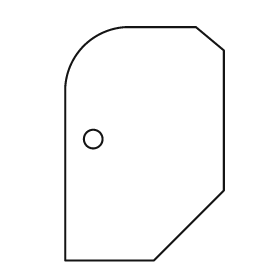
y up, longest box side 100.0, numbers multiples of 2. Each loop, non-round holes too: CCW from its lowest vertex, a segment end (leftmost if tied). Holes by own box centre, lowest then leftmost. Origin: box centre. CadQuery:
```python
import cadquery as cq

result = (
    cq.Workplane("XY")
    .moveTo(-34.0, -50.0)
    .lineTo(4.0, -50.0)
    .lineTo(34.0, -20.0)
    .lineTo(34.0, 40.0)
    .lineTo(22.0, 50.0)
    .lineTo(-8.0, 50.0)
    .threePointArc((-26.0, 42.0), (-34.0, 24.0))
    .close()
    .moveTo(-22.0, 2.0)
    .circle(4.0)
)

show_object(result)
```